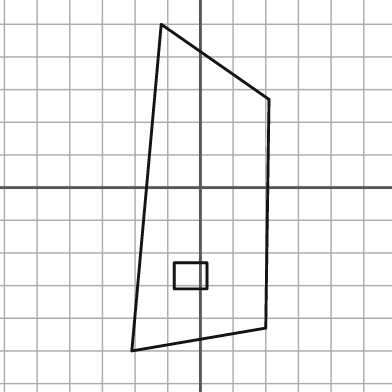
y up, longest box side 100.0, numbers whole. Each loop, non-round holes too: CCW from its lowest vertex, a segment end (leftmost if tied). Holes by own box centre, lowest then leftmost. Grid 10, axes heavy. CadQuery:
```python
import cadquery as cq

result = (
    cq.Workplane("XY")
    .moveTo(-21.0, -50.0)
    .lineTo(20.0, -43.0)
    .lineTo(21.0, 27.0)
    .lineTo(-12.0, 50.0)
    .close()
    .moveTo(-8.0, -31.0)
    .lineTo(2.0, -31.0)
    .lineTo(2.0, -23.0)
    .lineTo(-8.0, -23.0)
    .close()
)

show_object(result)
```